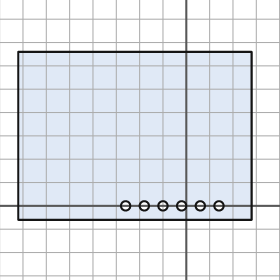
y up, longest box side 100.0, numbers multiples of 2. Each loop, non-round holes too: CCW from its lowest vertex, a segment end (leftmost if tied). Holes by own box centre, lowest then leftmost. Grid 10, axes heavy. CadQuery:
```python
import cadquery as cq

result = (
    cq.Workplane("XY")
    .moveTo(-72.0, -6.0)
    .lineTo(28.0, -6.0)
    .lineTo(28.0, 66.0)
    .lineTo(-72.0, 66.0)
    .close()
    .moveTo(-26.0, 0.0)
    .circle(2.0)
    .moveTo(-18.0, 0.0)
    .circle(2.0)
    .moveTo(-10.0, 0.0)
    .circle(2.0)
    .moveTo(-2.0, 0.0)
    .circle(2.0)
    .moveTo(6.0, 0.0)
    .circle(2.0)
    .moveTo(14.0, 0.0)
    .circle(2.0)
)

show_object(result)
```